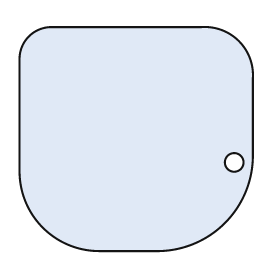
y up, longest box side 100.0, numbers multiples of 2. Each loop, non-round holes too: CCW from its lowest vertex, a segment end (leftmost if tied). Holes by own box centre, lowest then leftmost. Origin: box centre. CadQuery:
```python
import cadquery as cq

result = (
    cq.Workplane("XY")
    .moveTo(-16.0, -48.0)
    .lineTo(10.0, -48.0)
    .threePointArc((38.0, -36.0), (50.0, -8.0))
    .lineTo(50.0, 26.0)
    .threePointArc((44.0, 42.0), (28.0, 48.0))
    .lineTo(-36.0, 48.0)
    .threePointArc((-46.0, 44.0), (-50.0, 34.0))
    .lineTo(-50.0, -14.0)
    .threePointArc((-40.0, -38.0), (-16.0, -48.0))
    .close()
    .moveTo(42.0, -10.0)
    .circle(4.0)
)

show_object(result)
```